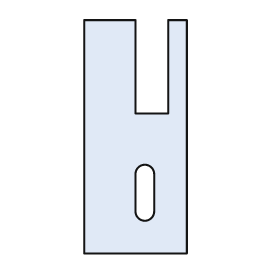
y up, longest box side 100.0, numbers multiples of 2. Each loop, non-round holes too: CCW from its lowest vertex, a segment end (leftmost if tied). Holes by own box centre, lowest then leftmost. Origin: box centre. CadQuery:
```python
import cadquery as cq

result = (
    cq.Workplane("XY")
    .moveTo(-22.0, -50.0)
    .lineTo(22.0, -50.0)
    .lineTo(22.0, 50.0)
    .lineTo(14.0, 50.0)
    .lineTo(14.0, 10.0)
    .lineTo(0.0, 10.0)
    .lineTo(0.0, 50.0)
    .lineTo(-22.0, 50.0)
    .close()
    .moveTo(0.0, -32.0)
    .threePointArc((4.0, -36.0), (8.0, -32.0))
    .lineTo(8.0, -16.0)
    .threePointArc((4.0, -12.0), (0.0, -16.0))
    .close()
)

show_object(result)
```